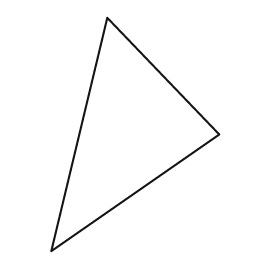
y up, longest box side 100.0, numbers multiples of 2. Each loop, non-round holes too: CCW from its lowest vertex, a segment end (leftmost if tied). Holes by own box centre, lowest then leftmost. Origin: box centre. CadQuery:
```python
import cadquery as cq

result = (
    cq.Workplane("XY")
    .moveTo(-36.0, -50.0)
    .lineTo(36.0, 0.0)
    .lineTo(-12.0, 50.0)
    .close()
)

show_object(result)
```